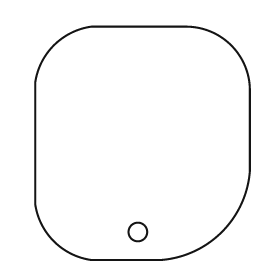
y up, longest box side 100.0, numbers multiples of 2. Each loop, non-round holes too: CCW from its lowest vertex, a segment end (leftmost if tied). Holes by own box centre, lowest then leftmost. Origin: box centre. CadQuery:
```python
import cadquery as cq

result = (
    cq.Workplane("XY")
    .moveTo(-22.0, -50.0)
    .lineTo(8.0, -50.0)
    .threePointArc((34.0, -38.0), (46.0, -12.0))
    .lineTo(46.0, 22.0)
    .threePointArc((38.0, 42.0), (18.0, 50.0))
    .lineTo(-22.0, 50.0)
    .threePointArc((-38.0, 42.0), (-46.0, 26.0))
    .lineTo(-46.0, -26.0)
    .threePointArc((-38.0, -42.0), (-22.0, -50.0))
    .close()
    .moveTo(-2.0, -38.0)
    .circle(4.0)
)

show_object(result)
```